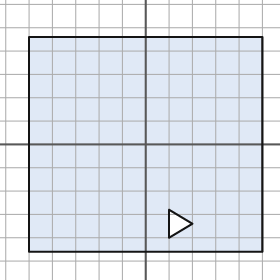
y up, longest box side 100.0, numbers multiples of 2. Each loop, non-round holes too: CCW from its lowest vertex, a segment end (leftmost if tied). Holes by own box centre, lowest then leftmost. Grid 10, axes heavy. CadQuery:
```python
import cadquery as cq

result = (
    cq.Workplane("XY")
    .moveTo(-50.0, -46.0)
    .lineTo(50.0, -46.0)
    .lineTo(50.0, 46.0)
    .lineTo(-50.0, 46.0)
    .close()
    .moveTo(10.0, -40.0)
    .lineTo(20.0, -34.0)
    .lineTo(10.0, -28.0)
    .close()
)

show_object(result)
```